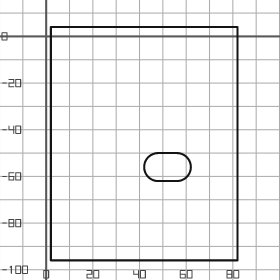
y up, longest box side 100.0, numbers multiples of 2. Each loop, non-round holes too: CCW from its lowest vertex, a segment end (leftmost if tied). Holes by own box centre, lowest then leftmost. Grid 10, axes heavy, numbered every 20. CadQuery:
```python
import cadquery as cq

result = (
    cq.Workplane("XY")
    .moveTo(2.0, -96.0)
    .lineTo(82.0, -96.0)
    .lineTo(82.0, 4.0)
    .lineTo(2.0, 4.0)
    .close()
    .moveTo(48.0, -62.0)
    .lineTo(56.0, -62.0)
    .threePointArc((62.0, -56.0), (56.0, -50.0))
    .lineTo(48.0, -50.0)
    .threePointArc((42.0, -56.0), (48.0, -62.0))
    .close()
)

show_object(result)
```